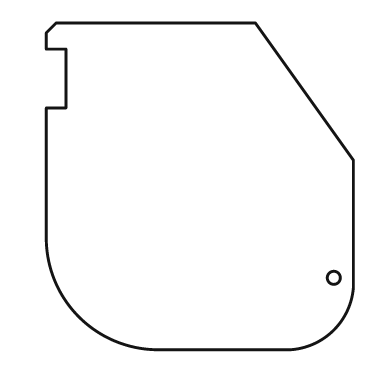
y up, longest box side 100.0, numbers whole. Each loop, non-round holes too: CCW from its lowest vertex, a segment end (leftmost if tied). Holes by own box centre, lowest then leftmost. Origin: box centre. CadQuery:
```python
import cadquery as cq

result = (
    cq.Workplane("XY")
    .moveTo(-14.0, -50.0)
    .lineTo(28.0, -50.0)
    .threePointArc((41.0, -44.0), (47.0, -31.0))
    .lineTo(47.0, 8.0)
    .lineTo(17.0, 50.0)
    .lineTo(-44.0, 50.0)
    .lineTo(-47.0, 47.0)
    .lineTo(-47.0, 42.0)
    .lineTo(-41.0, 42.0)
    .lineTo(-41.0, 24.0)
    .lineTo(-47.0, 24.0)
    .lineTo(-47.0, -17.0)
    .threePointArc((-37.0, -40.0), (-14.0, -50.0))
    .close()
    .moveTo(41.0, -28.0)
    .circle(2.0)
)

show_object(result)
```